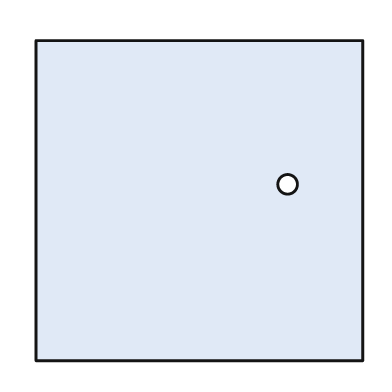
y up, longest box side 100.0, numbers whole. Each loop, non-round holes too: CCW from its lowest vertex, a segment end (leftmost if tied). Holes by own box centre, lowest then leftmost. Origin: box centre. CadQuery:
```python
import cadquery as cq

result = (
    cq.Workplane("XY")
    .moveTo(-50.0, -49.0)
    .lineTo(50.0, -49.0)
    .lineTo(50.0, 49.0)
    .lineTo(-50.0, 49.0)
    .close()
    .moveTo(27.0, 5.0)
    .circle(3.0)
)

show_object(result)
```